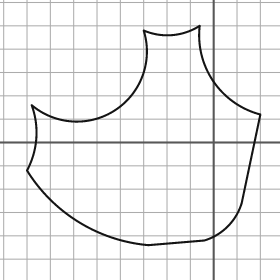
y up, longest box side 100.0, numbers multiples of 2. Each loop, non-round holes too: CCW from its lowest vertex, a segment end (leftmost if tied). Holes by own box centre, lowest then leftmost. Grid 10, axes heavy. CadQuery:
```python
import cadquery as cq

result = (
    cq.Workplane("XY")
    .moveTo(-28.0, -44.0)
    .lineTo(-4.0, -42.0)
    .threePointArc((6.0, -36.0), (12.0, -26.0))
    .lineTo(20.0, 12.0)
    .threePointArc((0.0, 26.0), (-6.0, 50.0))
    .threePointArc((-18.0, 46.0), (-30.0, 48.0))
    .threePointArc((-42.0, 14.0), (-78.0, 16.0))
    .threePointArc((-76.0, 2.0), (-80.0, -12.0))
    .threePointArc((-58.0, -34.0), (-28.0, -44.0))
    .close()
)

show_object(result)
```